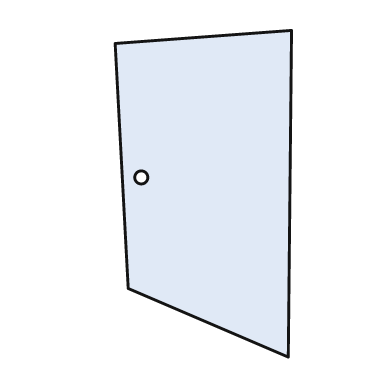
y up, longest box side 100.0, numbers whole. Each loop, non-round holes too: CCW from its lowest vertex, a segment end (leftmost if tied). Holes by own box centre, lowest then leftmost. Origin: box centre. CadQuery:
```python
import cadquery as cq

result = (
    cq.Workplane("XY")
    .moveTo(26.0, -50.0)
    .lineTo(27.0, 50.0)
    .lineTo(-27.0, 46.0)
    .lineTo(-23.0, -29.0)
    .close()
    .moveTo(-19.0, 5.0)
    .circle(2.0)
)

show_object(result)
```